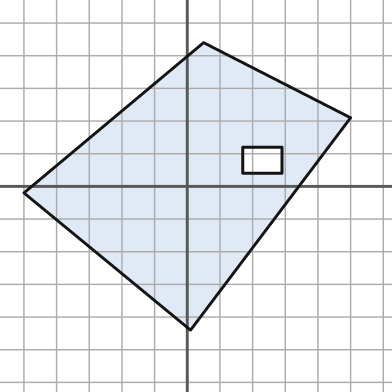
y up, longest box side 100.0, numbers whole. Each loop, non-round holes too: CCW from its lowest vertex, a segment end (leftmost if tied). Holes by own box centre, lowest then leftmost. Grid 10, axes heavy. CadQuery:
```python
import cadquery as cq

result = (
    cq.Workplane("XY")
    .moveTo(1.0, -44.0)
    .lineTo(50.0, 21.0)
    .lineTo(5.0, 44.0)
    .lineTo(-50.0, -2.0)
    .close()
    .moveTo(17.0, 4.0)
    .lineTo(29.0, 4.0)
    .lineTo(29.0, 12.0)
    .lineTo(17.0, 12.0)
    .close()
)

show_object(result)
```